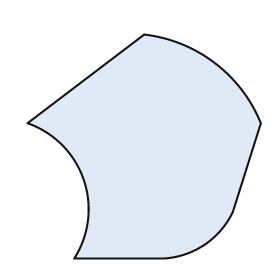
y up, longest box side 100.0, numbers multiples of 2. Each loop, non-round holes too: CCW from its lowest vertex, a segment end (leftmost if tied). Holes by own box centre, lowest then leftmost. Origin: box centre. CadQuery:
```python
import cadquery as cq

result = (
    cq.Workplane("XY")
    .moveTo(-30.0, -48.0)
    .lineTo(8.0, -48.0)
    .threePointArc((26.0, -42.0), (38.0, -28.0))
    .lineTo(50.0, 10.0)
    .threePointArc((30.0, 36.0), (0.0, 48.0))
    .lineTo(-50.0, 10.0)
    .threePointArc((-26.0, -14.0), (-30.0, -48.0))
    .close()
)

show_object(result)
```